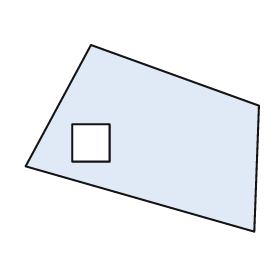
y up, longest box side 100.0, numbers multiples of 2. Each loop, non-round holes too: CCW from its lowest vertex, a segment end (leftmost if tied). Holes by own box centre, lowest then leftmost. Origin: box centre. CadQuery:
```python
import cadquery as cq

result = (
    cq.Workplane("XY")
    .moveTo(48.0, -40.0)
    .lineTo(50.0, 14.0)
    .lineTo(-22.0, 40.0)
    .lineTo(-50.0, -12.0)
    .close()
    .moveTo(-30.0, -10.0)
    .lineTo(-14.0, -10.0)
    .lineTo(-14.0, 6.0)
    .lineTo(-30.0, 6.0)
    .close()
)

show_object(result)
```